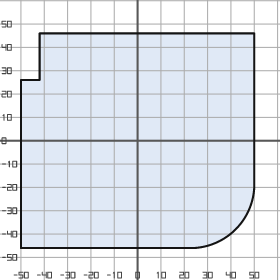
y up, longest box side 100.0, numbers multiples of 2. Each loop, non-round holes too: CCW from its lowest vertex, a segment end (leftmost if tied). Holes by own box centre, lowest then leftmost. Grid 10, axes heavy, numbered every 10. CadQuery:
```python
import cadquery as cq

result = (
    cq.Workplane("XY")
    .moveTo(-50.0, -46.0)
    .lineTo(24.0, -46.0)
    .threePointArc((42.0, -38.0), (50.0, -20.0))
    .lineTo(50.0, 46.0)
    .lineTo(-42.0, 46.0)
    .lineTo(-42.0, 26.0)
    .lineTo(-50.0, 26.0)
    .close()
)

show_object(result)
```